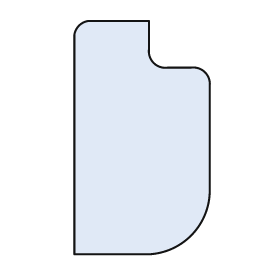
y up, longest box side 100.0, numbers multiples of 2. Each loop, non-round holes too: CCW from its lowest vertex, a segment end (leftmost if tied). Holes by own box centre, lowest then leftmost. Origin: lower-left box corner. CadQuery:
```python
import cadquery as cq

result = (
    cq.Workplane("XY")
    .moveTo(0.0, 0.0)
    .lineTo(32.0, 0.0)
    .threePointArc((50.0, 8.0), (58.0, 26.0))
    .lineTo(58.0, 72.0)
    .threePointArc((56.0, 78.0), (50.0, 80.0))
    .lineTo(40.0, 80.0)
    .threePointArc((34.0, 82.0), (32.0, 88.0))
    .lineTo(32.0, 100.0)
    .lineTo(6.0, 100.0)
    .threePointArc((2.0, 98.0), (0.0, 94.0))
    .close()
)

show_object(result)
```